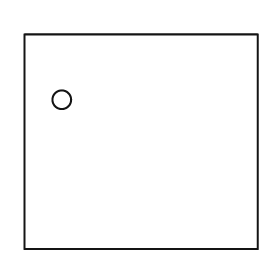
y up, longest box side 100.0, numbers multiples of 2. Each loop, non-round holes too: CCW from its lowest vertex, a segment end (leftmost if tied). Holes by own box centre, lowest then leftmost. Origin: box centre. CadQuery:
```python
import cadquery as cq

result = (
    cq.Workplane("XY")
    .moveTo(-50.0, -46.0)
    .lineTo(50.0, -46.0)
    .lineTo(50.0, 46.0)
    .lineTo(-50.0, 46.0)
    .close()
    .moveTo(-34.0, 18.0)
    .circle(4.0)
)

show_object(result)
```